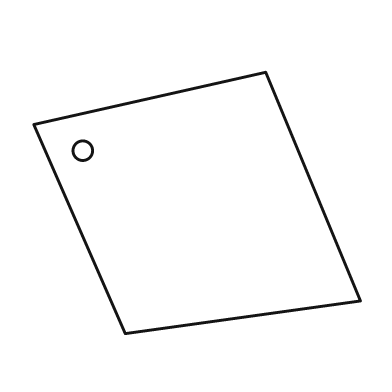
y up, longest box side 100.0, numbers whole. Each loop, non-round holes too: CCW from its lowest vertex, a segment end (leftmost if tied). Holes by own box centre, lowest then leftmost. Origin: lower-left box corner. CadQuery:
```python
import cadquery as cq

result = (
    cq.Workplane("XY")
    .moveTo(28.0, 0.0)
    .lineTo(100.0, 10.0)
    .lineTo(71.0, 80.0)
    .lineTo(0.0, 64.0)
    .close()
    .moveTo(15.0, 56.0)
    .circle(3.0)
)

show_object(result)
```